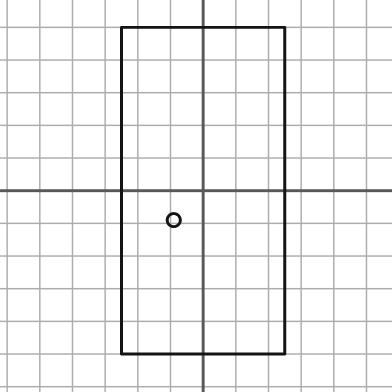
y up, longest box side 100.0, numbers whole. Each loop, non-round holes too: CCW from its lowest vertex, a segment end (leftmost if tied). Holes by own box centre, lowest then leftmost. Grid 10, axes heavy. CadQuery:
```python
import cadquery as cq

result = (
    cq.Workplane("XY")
    .moveTo(-25.0, -50.0)
    .lineTo(25.0, -50.0)
    .lineTo(25.0, 50.0)
    .lineTo(-25.0, 50.0)
    .close()
    .moveTo(-9.0, -9.0)
    .circle(2.0)
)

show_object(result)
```